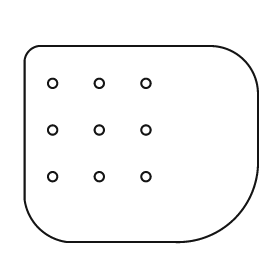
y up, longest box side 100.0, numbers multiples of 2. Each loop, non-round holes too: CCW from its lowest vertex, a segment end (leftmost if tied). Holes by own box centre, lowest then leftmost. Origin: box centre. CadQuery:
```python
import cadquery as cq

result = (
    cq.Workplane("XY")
    .moveTo(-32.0, -42.0)
    .lineTo(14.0, -42.0)
    .threePointArc((40.0, -32.0), (50.0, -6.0))
    .lineTo(50.0, 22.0)
    .threePointArc((44.0, 36.0), (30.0, 42.0))
    .lineTo(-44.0, 42.0)
    .threePointArc((-48.0, 40.0), (-50.0, 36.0))
    .lineTo(-50.0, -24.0)
    .threePointArc((-44.0, -36.0), (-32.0, -42.0))
    .close()
    .moveTo(-38.0, -14.0)
    .circle(2.0)
    .moveTo(-18.0, -14.0)
    .circle(2.0)
    .moveTo(2.0, -14.0)
    .circle(2.0)
    .moveTo(-38.0, 6.0)
    .circle(2.0)
    .moveTo(-18.0, 6.0)
    .circle(2.0)
    .moveTo(2.0, 6.0)
    .circle(2.0)
    .moveTo(-38.0, 26.0)
    .circle(2.0)
    .moveTo(-18.0, 26.0)
    .circle(2.0)
    .moveTo(2.0, 26.0)
    .circle(2.0)
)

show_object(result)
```